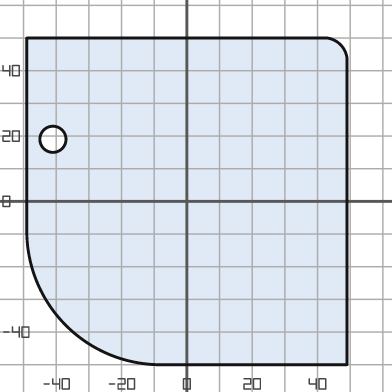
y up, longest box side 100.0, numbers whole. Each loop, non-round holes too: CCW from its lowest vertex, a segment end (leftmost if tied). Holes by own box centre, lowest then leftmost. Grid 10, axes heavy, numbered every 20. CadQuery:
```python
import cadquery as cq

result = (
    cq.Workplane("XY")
    .moveTo(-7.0, -50.0)
    .lineTo(49.0, -50.0)
    .lineTo(49.0, 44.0)
    .threePointArc((47.0, 48.0), (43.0, 50.0))
    .lineTo(-49.0, 50.0)
    .lineTo(-49.0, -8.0)
    .threePointArc((-37.0, -38.0), (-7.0, -50.0))
    .close()
    .moveTo(-41.0, 19.0)
    .circle(4.0)
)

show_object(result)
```